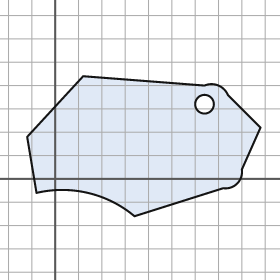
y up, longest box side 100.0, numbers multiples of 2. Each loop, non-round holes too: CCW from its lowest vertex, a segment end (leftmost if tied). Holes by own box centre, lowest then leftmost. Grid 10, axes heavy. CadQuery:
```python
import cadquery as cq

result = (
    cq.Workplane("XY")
    .moveTo(34.0, -16.0)
    .lineTo(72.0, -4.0)
    .threePointArc((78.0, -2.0), (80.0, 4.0))
    .lineTo(88.0, 22.0)
    .lineTo(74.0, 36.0)
    .threePointArc((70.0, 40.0), (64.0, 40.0))
    .lineTo(12.0, 44.0)
    .lineTo(-12.0, 18.0)
    .lineTo(-8.0, -6.0)
    .threePointArc((14.0, -6.0), (34.0, -16.0))
    .close()
    .moveTo(64.0, 32.0)
    .circle(4.0)
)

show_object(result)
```